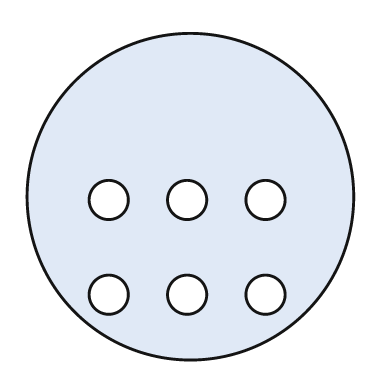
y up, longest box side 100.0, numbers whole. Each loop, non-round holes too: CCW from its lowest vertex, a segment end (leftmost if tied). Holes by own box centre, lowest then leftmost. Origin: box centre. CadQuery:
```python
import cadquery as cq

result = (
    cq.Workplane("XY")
    .moveTo(0.0, 0.0)
    .circle(50.0)
    .moveTo(-25.0, -30.0)
    .circle(6.0)
    .moveTo(-1.0, -30.0)
    .circle(6.0)
    .moveTo(23.0, -30.0)
    .circle(6.0)
    .moveTo(-25.0, -1.0)
    .circle(6.0)
    .moveTo(-1.0, -1.0)
    .circle(6.0)
    .moveTo(23.0, -1.0)
    .circle(6.0)
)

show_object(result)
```